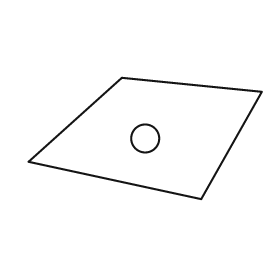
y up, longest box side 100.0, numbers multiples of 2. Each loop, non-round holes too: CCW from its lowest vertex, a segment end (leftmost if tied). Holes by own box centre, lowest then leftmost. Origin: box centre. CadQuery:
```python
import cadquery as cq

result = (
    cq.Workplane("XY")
    .moveTo(24.0, -26.0)
    .lineTo(50.0, 20.0)
    .lineTo(-10.0, 26.0)
    .lineTo(-50.0, -10.0)
    .close()
    .moveTo(0.0, 0.0)
    .circle(6.0)
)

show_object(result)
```